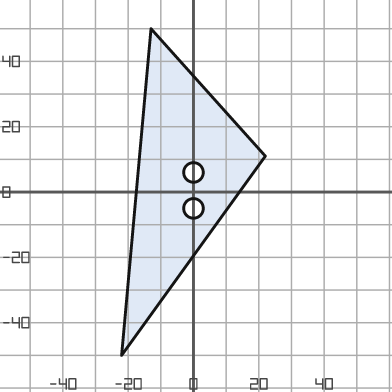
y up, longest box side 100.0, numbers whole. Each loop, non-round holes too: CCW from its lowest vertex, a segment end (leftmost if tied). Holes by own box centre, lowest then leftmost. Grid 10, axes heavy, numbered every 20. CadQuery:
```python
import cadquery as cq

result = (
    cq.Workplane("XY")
    .moveTo(-22.0, -50.0)
    .lineTo(22.0, 11.0)
    .lineTo(-13.0, 50.0)
    .close()
    .moveTo(0.0, -5.0)
    .circle(3.0)
    .moveTo(0.0, 6.0)
    .circle(3.0)
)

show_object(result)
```